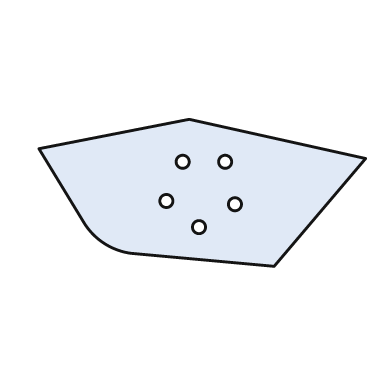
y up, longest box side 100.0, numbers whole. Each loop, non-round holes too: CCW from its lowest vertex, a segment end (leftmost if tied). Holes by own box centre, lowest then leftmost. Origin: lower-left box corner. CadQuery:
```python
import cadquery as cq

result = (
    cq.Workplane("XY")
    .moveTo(72.0, 0.0)
    .lineTo(100.0, 33.0)
    .lineTo(46.0, 45.0)
    .lineTo(0.0, 36.0)
    .lineTo(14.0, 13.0)
    .threePointArc((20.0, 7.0), (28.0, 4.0))
    .close()
    .moveTo(49.0, 12.0)
    .circle(2.0)
    .moveTo(60.0, 19.0)
    .circle(2.0)
    .moveTo(39.0, 20.0)
    .circle(2.0)
    .moveTo(44.0, 32.0)
    .circle(2.0)
    .moveTo(57.0, 32.0)
    .circle(2.0)
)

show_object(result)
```